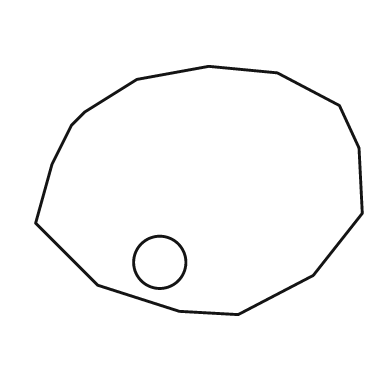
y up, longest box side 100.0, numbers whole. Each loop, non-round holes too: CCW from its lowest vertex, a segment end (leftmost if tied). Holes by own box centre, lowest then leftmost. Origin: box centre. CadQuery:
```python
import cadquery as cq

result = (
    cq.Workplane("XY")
    .moveTo(12.0, -38.0)
    .lineTo(35.0, -26.0)
    .lineTo(50.0, -7.0)
    .lineTo(49.0, 13.0)
    .lineTo(43.0, 26.0)
    .lineTo(24.0, 36.0)
    .lineTo(3.0, 38.0)
    .lineTo(-19.0, 34.0)
    .lineTo(-35.0, 24.0)
    .lineTo(-39.0, 20.0)
    .lineTo(-45.0, 8.0)
    .lineTo(-50.0, -10.0)
    .lineTo(-31.0, -29.0)
    .lineTo(-6.0, -37.0)
    .close()
    .moveTo(-12.0, -22.0)
    .circle(8.0)
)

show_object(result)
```